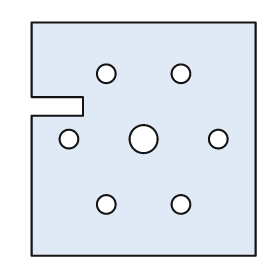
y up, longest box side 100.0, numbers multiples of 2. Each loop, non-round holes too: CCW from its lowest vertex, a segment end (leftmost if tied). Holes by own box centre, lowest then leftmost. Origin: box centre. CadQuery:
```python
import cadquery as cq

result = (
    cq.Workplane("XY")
    .moveTo(-48.0, -50.0)
    .lineTo(48.0, -50.0)
    .lineTo(48.0, 50.0)
    .lineTo(-48.0, 50.0)
    .lineTo(-48.0, 18.0)
    .lineTo(-26.0, 18.0)
    .lineTo(-26.0, 10.0)
    .lineTo(-48.0, 10.0)
    .close()
    .moveTo(-16.0, -28.0)
    .circle(4.0)
    .moveTo(16.0, -28.0)
    .circle(4.0)
    .moveTo(-32.0, 0.0)
    .circle(4.0)
    .moveTo(0.0, 0.0)
    .circle(6.0)
    .moveTo(32.0, 0.0)
    .circle(4.0)
    .moveTo(-16.0, 28.0)
    .circle(4.0)
    .moveTo(16.0, 28.0)
    .circle(4.0)
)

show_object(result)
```